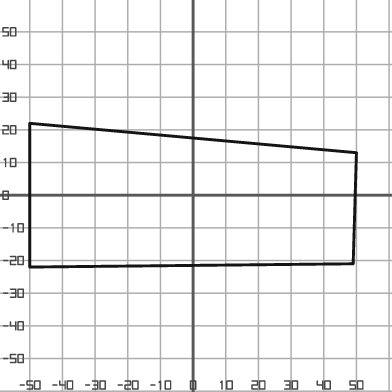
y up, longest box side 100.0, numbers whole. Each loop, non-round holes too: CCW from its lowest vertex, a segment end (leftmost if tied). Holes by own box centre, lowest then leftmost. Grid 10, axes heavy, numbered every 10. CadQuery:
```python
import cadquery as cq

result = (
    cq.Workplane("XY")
    .moveTo(-50.0, -22.0)
    .lineTo(49.0, -21.0)
    .lineTo(50.0, 13.0)
    .lineTo(-50.0, 22.0)
    .close()
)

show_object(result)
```